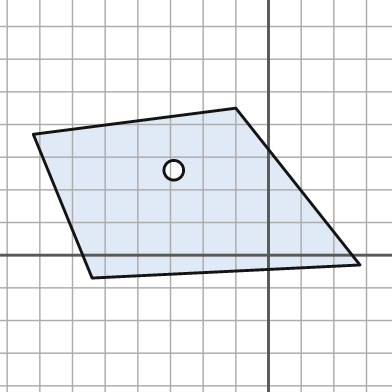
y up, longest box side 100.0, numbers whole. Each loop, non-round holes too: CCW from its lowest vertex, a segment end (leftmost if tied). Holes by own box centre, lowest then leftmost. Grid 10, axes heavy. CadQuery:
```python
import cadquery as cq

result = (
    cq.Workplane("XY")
    .moveTo(-54.0, -7.0)
    .lineTo(28.0, -3.0)
    .lineTo(-10.0, 45.0)
    .lineTo(-72.0, 37.0)
    .close()
    .moveTo(-29.0, 26.0)
    .circle(3.0)
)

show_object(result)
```